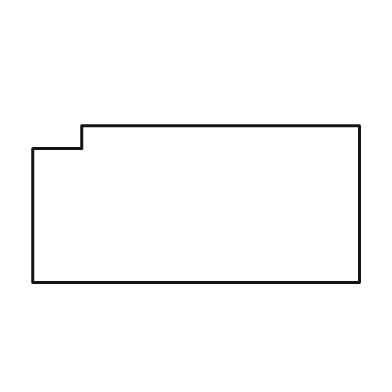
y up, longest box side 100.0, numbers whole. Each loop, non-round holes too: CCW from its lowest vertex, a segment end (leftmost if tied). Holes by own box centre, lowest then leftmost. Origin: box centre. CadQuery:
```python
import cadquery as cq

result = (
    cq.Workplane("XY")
    .moveTo(-50.0, -24.0)
    .lineTo(50.0, -24.0)
    .lineTo(50.0, 24.0)
    .lineTo(-35.0, 24.0)
    .lineTo(-35.0, 17.0)
    .lineTo(-50.0, 17.0)
    .close()
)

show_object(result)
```